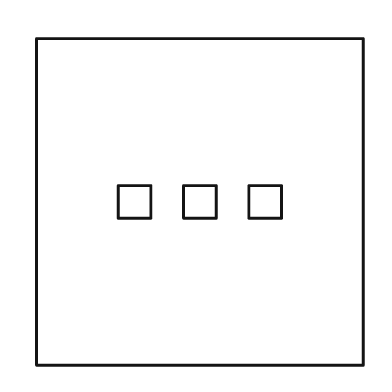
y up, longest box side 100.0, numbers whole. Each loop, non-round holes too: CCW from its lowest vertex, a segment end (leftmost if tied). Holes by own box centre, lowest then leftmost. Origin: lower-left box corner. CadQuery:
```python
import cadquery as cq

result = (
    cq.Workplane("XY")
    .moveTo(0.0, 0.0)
    .lineTo(100.0, 0.0)
    .lineTo(100.0, 100.0)
    .lineTo(0.0, 100.0)
    .close()
    .moveTo(25.0, 45.0)
    .lineTo(35.0, 45.0)
    .lineTo(35.0, 55.0)
    .lineTo(25.0, 55.0)
    .close()
    .moveTo(45.0, 45.0)
    .lineTo(55.0, 45.0)
    .lineTo(55.0, 55.0)
    .lineTo(45.0, 55.0)
    .close()
    .moveTo(65.0, 45.0)
    .lineTo(75.0, 45.0)
    .lineTo(75.0, 55.0)
    .lineTo(65.0, 55.0)
    .close()
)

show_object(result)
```